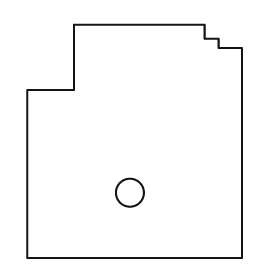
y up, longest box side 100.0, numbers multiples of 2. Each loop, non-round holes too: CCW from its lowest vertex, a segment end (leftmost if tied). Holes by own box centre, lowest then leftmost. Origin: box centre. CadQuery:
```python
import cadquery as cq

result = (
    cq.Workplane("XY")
    .moveTo(-46.0, -50.0)
    .lineTo(46.0, -50.0)
    .lineTo(46.0, 40.0)
    .lineTo(36.0, 40.0)
    .lineTo(36.0, 44.0)
    .lineTo(30.0, 44.0)
    .lineTo(30.0, 50.0)
    .lineTo(-26.0, 50.0)
    .lineTo(-26.0, 22.0)
    .lineTo(-46.0, 22.0)
    .close()
    .moveTo(-2.0, -22.0)
    .circle(6.0)
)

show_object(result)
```